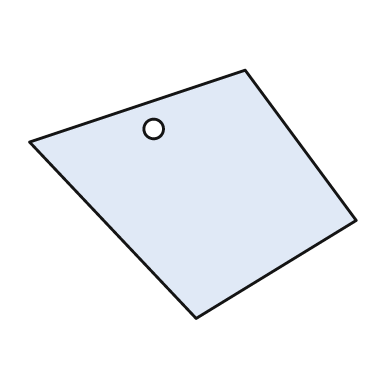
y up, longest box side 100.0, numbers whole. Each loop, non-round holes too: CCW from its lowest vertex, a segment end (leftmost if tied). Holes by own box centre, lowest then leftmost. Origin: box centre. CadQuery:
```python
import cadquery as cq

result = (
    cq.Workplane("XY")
    .moveTo(1.0, -38.0)
    .lineTo(50.0, -8.0)
    .lineTo(16.0, 38.0)
    .lineTo(-50.0, 16.0)
    .close()
    .moveTo(-12.0, 20.0)
    .circle(3.0)
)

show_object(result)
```